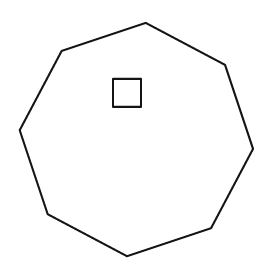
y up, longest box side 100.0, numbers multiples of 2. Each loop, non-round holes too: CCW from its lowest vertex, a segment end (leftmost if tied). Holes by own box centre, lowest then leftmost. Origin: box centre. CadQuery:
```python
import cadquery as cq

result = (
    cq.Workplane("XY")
    .moveTo(-4.0, -50.0)
    .lineTo(32.0, -38.0)
    .lineTo(50.0, -4.0)
    .lineTo(38.0, 32.0)
    .lineTo(4.0, 50.0)
    .lineTo(-32.0, 38.0)
    .lineTo(-50.0, 4.0)
    .lineTo(-38.0, -32.0)
    .close()
    .moveTo(-10.0, 14.0)
    .lineTo(2.0, 14.0)
    .lineTo(2.0, 26.0)
    .lineTo(-10.0, 26.0)
    .close()
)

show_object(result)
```